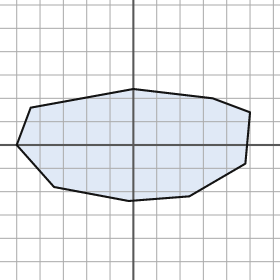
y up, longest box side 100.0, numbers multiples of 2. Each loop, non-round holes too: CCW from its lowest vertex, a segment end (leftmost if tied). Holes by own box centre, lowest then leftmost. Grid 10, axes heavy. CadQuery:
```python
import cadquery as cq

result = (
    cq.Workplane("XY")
    .moveTo(-2.0, -24.0)
    .lineTo(24.0, -22.0)
    .lineTo(48.0, -8.0)
    .lineTo(50.0, 14.0)
    .lineTo(34.0, 20.0)
    .lineTo(0.0, 24.0)
    .lineTo(-44.0, 16.0)
    .lineTo(-50.0, 0.0)
    .lineTo(-34.0, -18.0)
    .close()
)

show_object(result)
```